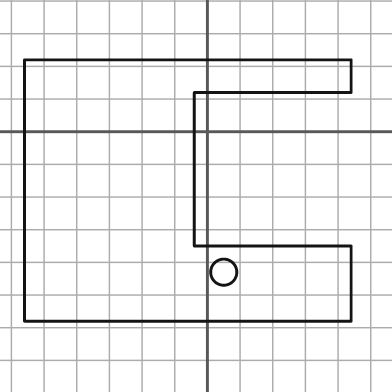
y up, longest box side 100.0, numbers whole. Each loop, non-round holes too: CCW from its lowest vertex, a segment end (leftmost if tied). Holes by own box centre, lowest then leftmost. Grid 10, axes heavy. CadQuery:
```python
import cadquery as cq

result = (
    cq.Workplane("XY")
    .moveTo(-56.0, -58.0)
    .lineTo(44.0, -58.0)
    .lineTo(44.0, -35.0)
    .lineTo(-4.0, -35.0)
    .lineTo(-4.0, 12.0)
    .lineTo(44.0, 12.0)
    .lineTo(44.0, 22.0)
    .lineTo(-56.0, 22.0)
    .close()
    .moveTo(5.0, -43.0)
    .circle(4.0)
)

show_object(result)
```